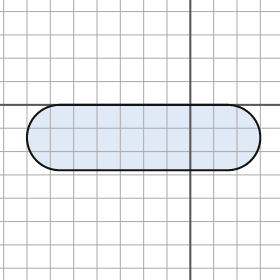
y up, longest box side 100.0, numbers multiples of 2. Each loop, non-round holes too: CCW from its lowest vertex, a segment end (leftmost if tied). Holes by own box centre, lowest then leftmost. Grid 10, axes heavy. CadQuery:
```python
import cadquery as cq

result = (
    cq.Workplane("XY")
    .moveTo(-56.0, -28.0)
    .lineTo(16.0, -28.0)
    .threePointArc((30.0, -14.0), (16.0, 0.0))
    .lineTo(-56.0, 0.0)
    .threePointArc((-70.0, -14.0), (-56.0, -28.0))
    .close()
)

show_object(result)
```